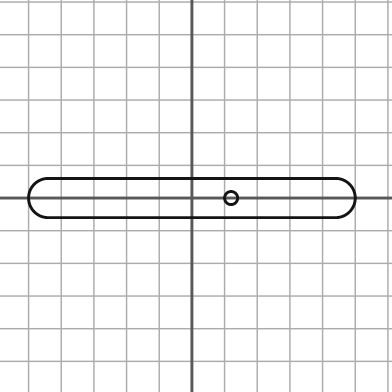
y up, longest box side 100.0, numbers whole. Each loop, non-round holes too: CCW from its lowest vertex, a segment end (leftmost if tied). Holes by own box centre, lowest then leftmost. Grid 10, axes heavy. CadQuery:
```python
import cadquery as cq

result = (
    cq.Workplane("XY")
    .moveTo(-44.0, -6.0)
    .lineTo(44.0, -6.0)
    .threePointArc((50.0, 0.0), (44.0, 6.0))
    .lineTo(-44.0, 6.0)
    .threePointArc((-50.0, 0.0), (-44.0, -6.0))
    .close()
    .moveTo(12.0, 0.0)
    .circle(2.0)
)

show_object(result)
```